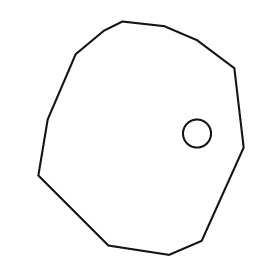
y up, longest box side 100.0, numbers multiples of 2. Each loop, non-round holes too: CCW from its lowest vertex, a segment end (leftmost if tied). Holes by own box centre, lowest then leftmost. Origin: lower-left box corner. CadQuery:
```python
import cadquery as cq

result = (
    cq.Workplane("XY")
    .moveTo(56.0, 0.0)
    .lineTo(70.0, 6.0)
    .lineTo(88.0, 46.0)
    .lineTo(84.0, 80.0)
    .lineTo(68.0, 92.0)
    .lineTo(54.0, 98.0)
    .lineTo(36.0, 100.0)
    .lineTo(28.0, 96.0)
    .lineTo(16.0, 86.0)
    .lineTo(4.0, 58.0)
    .lineTo(0.0, 34.0)
    .lineTo(30.0, 4.0)
    .close()
    .moveTo(68.0, 52.0)
    .circle(6.0)
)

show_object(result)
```